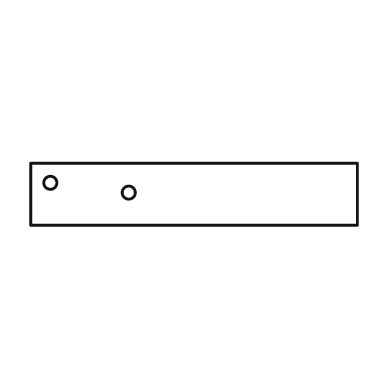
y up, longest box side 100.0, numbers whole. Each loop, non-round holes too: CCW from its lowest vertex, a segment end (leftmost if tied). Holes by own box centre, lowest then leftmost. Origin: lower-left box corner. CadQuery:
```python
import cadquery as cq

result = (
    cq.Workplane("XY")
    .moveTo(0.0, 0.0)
    .lineTo(100.0, 0.0)
    .lineTo(100.0, 19.0)
    .lineTo(0.0, 19.0)
    .close()
    .moveTo(30.0, 10.0)
    .circle(2.0)
    .moveTo(6.0, 13.0)
    .circle(2.0)
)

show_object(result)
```